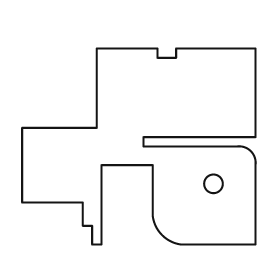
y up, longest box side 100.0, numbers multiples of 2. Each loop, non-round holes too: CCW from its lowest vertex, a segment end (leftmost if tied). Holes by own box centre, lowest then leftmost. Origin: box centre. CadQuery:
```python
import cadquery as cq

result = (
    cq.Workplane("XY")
    .moveTo(-20.0, -42.0)
    .lineTo(-16.0, -42.0)
    .lineTo(-16.0, -8.0)
    .lineTo(6.0, -8.0)
    .lineTo(6.0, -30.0)
    .threePointArc((10.0, -38.0), (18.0, -42.0))
    .lineTo(50.0, -42.0)
    .lineTo(50.0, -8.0)
    .threePointArc((48.0, -2.0), (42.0, 0.0))
    .lineTo(2.0, 0.0)
    .lineTo(2.0, 4.0)
    .lineTo(50.0, 4.0)
    .lineTo(50.0, 42.0)
    .lineTo(16.0, 42.0)
    .lineTo(16.0, 38.0)
    .lineTo(8.0, 38.0)
    .lineTo(8.0, 42.0)
    .lineTo(-18.0, 42.0)
    .lineTo(-18.0, 8.0)
    .lineTo(-50.0, 8.0)
    .lineTo(-50.0, -24.0)
    .lineTo(-24.0, -24.0)
    .lineTo(-24.0, -34.0)
    .lineTo(-20.0, -34.0)
    .close()
    .moveTo(32.0, -16.0)
    .circle(4.0)
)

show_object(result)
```